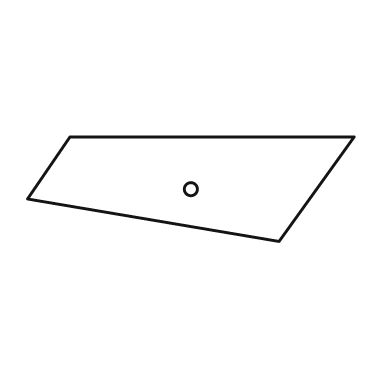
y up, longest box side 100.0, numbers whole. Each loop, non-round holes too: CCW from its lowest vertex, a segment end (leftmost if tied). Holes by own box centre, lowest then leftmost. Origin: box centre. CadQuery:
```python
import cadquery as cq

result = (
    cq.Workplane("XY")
    .moveTo(27.0, -16.0)
    .lineTo(50.0, 16.0)
    .lineTo(-37.0, 16.0)
    .lineTo(-50.0, -3.0)
    .close()
    .moveTo(0.0, 0.0)
    .circle(2.0)
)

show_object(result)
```